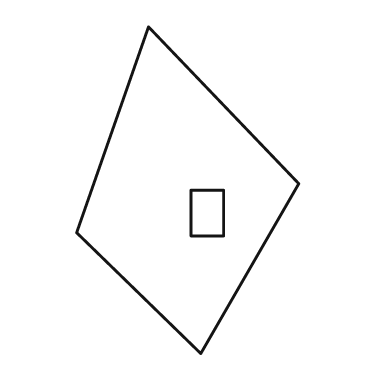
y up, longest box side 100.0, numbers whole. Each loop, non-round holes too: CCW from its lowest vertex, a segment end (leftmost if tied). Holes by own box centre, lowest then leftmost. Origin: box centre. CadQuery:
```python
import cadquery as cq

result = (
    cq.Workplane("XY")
    .moveTo(4.0, -50.0)
    .lineTo(34.0, 2.0)
    .lineTo(-12.0, 50.0)
    .lineTo(-34.0, -13.0)
    .close()
    .moveTo(1.0, -14.0)
    .lineTo(11.0, -14.0)
    .lineTo(11.0, 0.0)
    .lineTo(1.0, 0.0)
    .close()
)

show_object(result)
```